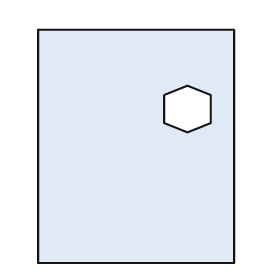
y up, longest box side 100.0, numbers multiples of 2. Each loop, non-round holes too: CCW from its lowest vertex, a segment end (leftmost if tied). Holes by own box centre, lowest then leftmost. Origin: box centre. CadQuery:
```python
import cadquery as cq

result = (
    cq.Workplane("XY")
    .moveTo(-42.0, -50.0)
    .lineTo(42.0, -50.0)
    .lineTo(42.0, 50.0)
    .lineTo(-42.0, 50.0)
    .close()
    .moveTo(22.0, 6.0)
    .lineTo(32.0, 10.0)
    .lineTo(32.0, 22.0)
    .lineTo(22.0, 26.0)
    .lineTo(12.0, 22.0)
    .lineTo(12.0, 10.0)
    .close()
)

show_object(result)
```